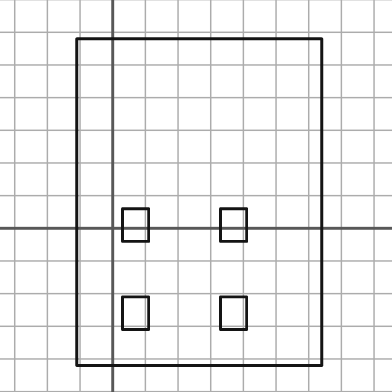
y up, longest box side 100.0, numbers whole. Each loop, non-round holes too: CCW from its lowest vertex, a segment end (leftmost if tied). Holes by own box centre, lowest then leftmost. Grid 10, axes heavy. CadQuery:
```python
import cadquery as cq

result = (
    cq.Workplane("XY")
    .moveTo(-11.0, -42.0)
    .lineTo(64.0, -42.0)
    .lineTo(64.0, 58.0)
    .lineTo(-11.0, 58.0)
    .close()
    .moveTo(3.0, -31.0)
    .lineTo(11.0, -31.0)
    .lineTo(11.0, -21.0)
    .lineTo(3.0, -21.0)
    .close()
    .moveTo(33.0, -31.0)
    .lineTo(41.0, -31.0)
    .lineTo(41.0, -21.0)
    .lineTo(33.0, -21.0)
    .close()
    .moveTo(3.0, -4.0)
    .lineTo(11.0, -4.0)
    .lineTo(11.0, 6.0)
    .lineTo(3.0, 6.0)
    .close()
    .moveTo(33.0, -4.0)
    .lineTo(41.0, -4.0)
    .lineTo(41.0, 6.0)
    .lineTo(33.0, 6.0)
    .close()
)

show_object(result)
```